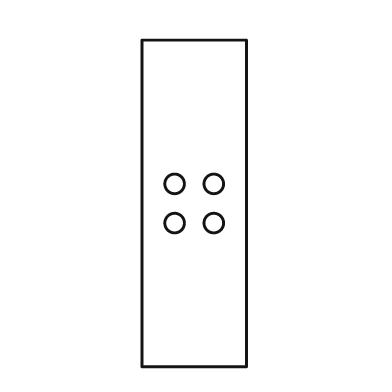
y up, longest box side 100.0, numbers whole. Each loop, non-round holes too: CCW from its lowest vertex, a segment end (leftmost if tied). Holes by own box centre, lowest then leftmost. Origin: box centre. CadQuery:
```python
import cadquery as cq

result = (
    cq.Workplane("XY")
    .moveTo(-16.0, -50.0)
    .lineTo(16.0, -50.0)
    .lineTo(16.0, 50.0)
    .lineTo(-16.0, 50.0)
    .close()
    .moveTo(-6.0, -6.0)
    .circle(3.0)
    .moveTo(6.0, -6.0)
    .circle(3.0)
    .moveTo(-6.0, 6.0)
    .circle(3.0)
    .moveTo(6.0, 6.0)
    .circle(3.0)
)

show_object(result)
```